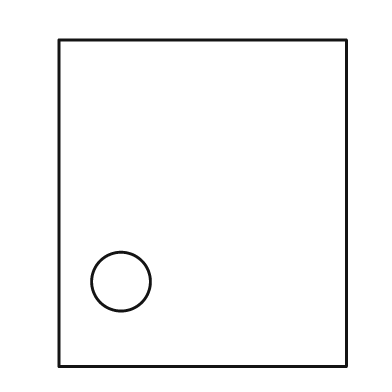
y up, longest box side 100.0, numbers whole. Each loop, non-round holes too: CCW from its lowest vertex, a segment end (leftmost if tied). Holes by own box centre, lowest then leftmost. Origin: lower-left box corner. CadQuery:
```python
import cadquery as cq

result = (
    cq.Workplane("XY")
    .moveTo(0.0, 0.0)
    .lineTo(88.0, 0.0)
    .lineTo(88.0, 100.0)
    .lineTo(0.0, 100.0)
    .close()
    .moveTo(19.0, 26.0)
    .circle(9.0)
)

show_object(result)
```